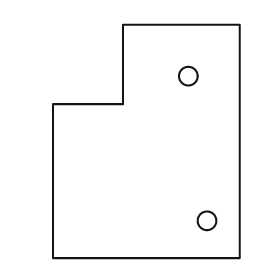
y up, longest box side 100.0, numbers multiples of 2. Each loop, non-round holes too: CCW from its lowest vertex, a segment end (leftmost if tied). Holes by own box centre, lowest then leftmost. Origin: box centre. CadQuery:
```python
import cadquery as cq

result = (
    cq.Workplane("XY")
    .moveTo(-40.0, -50.0)
    .lineTo(40.0, -50.0)
    .lineTo(40.0, 50.0)
    .lineTo(-10.0, 50.0)
    .lineTo(-10.0, 16.0)
    .lineTo(-40.0, 16.0)
    .close()
    .moveTo(26.0, -34.0)
    .circle(4.0)
    .moveTo(18.0, 28.0)
    .circle(4.0)
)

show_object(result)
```